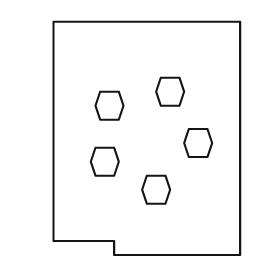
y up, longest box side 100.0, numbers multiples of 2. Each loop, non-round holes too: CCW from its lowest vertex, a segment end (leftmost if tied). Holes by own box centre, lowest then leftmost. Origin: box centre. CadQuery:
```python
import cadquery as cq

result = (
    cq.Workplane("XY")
    .moveTo(-14.0, -50.0)
    .lineTo(40.0, -50.0)
    .lineTo(40.0, 50.0)
    .lineTo(-40.0, 50.0)
    .lineTo(-40.0, -44.0)
    .lineTo(-14.0, -44.0)
    .close()
    .moveTo(0.0, -28.0)
    .lineTo(8.0, -28.0)
    .lineTo(10.0, -22.0)
    .lineTo(8.0, -16.0)
    .lineTo(0.0, -16.0)
    .lineTo(-2.0, -22.0)
    .close()
    .moveTo(-22.0, -16.0)
    .lineTo(-14.0, -16.0)
    .lineTo(-12.0, -10.0)
    .lineTo(-14.0, -4.0)
    .lineTo(-22.0, -4.0)
    .lineTo(-24.0, -10.0)
    .close()
    .moveTo(18.0, -8.0)
    .lineTo(26.0, -8.0)
    .lineTo(28.0, -2.0)
    .lineTo(26.0, 4.0)
    .lineTo(18.0, 4.0)
    .lineTo(16.0, -2.0)
    .close()
    .moveTo(-20.0, 8.0)
    .lineTo(-12.0, 8.0)
    .lineTo(-10.0, 14.0)
    .lineTo(-12.0, 20.0)
    .lineTo(-20.0, 20.0)
    .lineTo(-22.0, 14.0)
    .close()
    .moveTo(6.0, 14.0)
    .lineTo(14.0, 14.0)
    .lineTo(16.0, 20.0)
    .lineTo(14.0, 26.0)
    .lineTo(6.0, 26.0)
    .lineTo(4.0, 20.0)
    .close()
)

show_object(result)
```